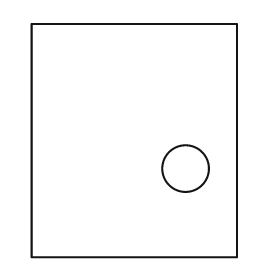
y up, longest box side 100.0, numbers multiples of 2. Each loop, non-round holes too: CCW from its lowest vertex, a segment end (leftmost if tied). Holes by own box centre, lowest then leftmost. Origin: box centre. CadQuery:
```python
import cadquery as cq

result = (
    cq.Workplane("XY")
    .moveTo(-44.0, -50.0)
    .lineTo(44.0, -50.0)
    .lineTo(44.0, 50.0)
    .lineTo(-44.0, 50.0)
    .close()
    .moveTo(22.0, -12.0)
    .circle(10.0)
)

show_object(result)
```